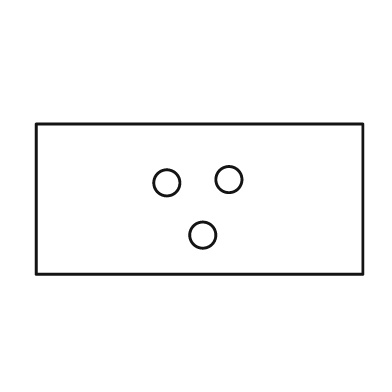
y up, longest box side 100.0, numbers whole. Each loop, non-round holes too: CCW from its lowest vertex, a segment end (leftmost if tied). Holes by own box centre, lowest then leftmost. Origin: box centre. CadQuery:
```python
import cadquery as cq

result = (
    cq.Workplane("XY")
    .moveTo(-50.0, -23.0)
    .lineTo(50.0, -23.0)
    .lineTo(50.0, 23.0)
    .lineTo(-50.0, 23.0)
    .close()
    .moveTo(1.0, -11.0)
    .circle(4.0)
    .moveTo(-10.0, 5.0)
    .circle(4.0)
    .moveTo(9.0, 6.0)
    .circle(4.0)
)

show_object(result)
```